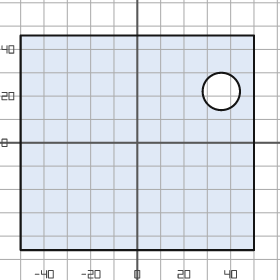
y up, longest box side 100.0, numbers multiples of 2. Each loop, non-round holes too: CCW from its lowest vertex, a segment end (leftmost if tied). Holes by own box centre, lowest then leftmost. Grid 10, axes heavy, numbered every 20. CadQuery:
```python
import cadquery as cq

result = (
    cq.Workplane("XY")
    .moveTo(-50.0, -46.0)
    .lineTo(50.0, -46.0)
    .lineTo(50.0, 46.0)
    .lineTo(-50.0, 46.0)
    .close()
    .moveTo(36.0, 22.0)
    .circle(8.0)
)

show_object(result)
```